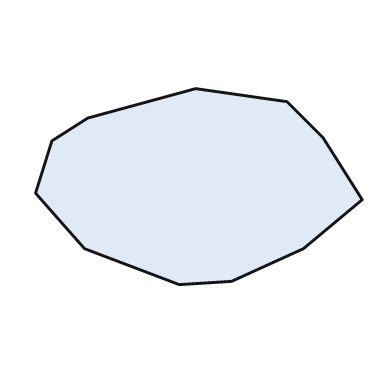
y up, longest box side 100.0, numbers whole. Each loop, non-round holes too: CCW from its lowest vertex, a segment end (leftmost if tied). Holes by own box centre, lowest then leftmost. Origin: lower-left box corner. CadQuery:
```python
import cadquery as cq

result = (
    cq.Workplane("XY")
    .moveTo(44.0, 0.0)
    .lineTo(60.0, 1.0)
    .lineTo(82.0, 11.0)
    .lineTo(100.0, 26.0)
    .lineTo(88.0, 45.0)
    .lineTo(77.0, 56.0)
    .lineTo(49.0, 60.0)
    .lineTo(16.0, 51.0)
    .lineTo(5.0, 44.0)
    .lineTo(0.0, 28.0)
    .lineTo(15.0, 11.0)
    .close()
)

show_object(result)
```